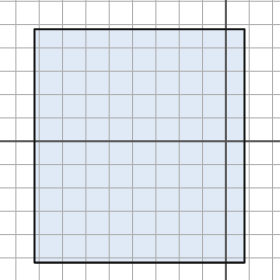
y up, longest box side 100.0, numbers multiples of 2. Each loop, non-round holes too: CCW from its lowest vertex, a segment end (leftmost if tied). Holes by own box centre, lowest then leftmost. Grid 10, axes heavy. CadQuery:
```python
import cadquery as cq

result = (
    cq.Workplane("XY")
    .moveTo(-82.0, -52.0)
    .lineTo(8.0, -52.0)
    .lineTo(8.0, 48.0)
    .lineTo(-82.0, 48.0)
    .close()
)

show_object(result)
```